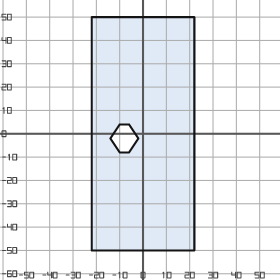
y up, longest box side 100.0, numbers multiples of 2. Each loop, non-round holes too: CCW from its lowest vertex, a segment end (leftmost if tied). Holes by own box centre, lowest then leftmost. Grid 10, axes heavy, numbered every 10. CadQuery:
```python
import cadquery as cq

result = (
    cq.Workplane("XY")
    .moveTo(-22.0, -50.0)
    .lineTo(22.0, -50.0)
    .lineTo(22.0, 50.0)
    .lineTo(-22.0, 50.0)
    .close()
    .moveTo(-10.0, -8.0)
    .lineTo(-6.0, -8.0)
    .lineTo(-2.0, -2.0)
    .lineTo(-6.0, 4.0)
    .lineTo(-10.0, 4.0)
    .lineTo(-14.0, -2.0)
    .close()
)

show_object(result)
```